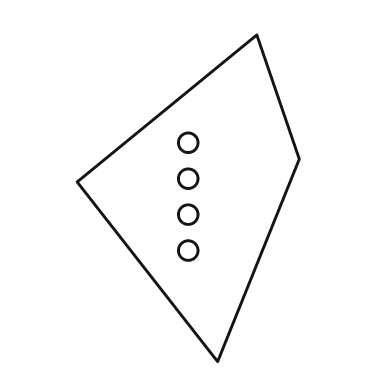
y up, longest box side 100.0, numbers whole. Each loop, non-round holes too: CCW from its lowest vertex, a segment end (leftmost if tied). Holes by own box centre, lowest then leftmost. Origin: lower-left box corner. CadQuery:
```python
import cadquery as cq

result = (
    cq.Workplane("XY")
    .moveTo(43.0, 0.0)
    .lineTo(68.0, 62.0)
    .lineTo(55.0, 100.0)
    .lineTo(0.0, 55.0)
    .close()
    .moveTo(34.0, 34.0)
    .circle(3.0)
    .moveTo(34.0, 45.0)
    .circle(3.0)
    .moveTo(34.0, 56.0)
    .circle(3.0)
    .moveTo(34.0, 67.0)
    .circle(3.0)
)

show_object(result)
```